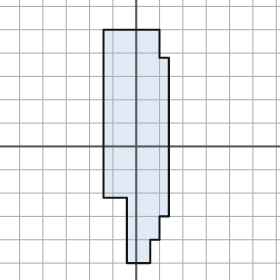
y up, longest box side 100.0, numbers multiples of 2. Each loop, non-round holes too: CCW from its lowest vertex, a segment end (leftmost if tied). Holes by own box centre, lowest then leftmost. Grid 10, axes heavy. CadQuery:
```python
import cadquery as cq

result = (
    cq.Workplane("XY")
    .moveTo(-4.0, -50.0)
    .lineTo(6.0, -50.0)
    .lineTo(6.0, -40.0)
    .lineTo(10.0, -40.0)
    .lineTo(10.0, -30.0)
    .lineTo(14.0, -30.0)
    .lineTo(14.0, 38.0)
    .lineTo(10.0, 38.0)
    .lineTo(10.0, 50.0)
    .lineTo(-14.0, 50.0)
    .lineTo(-14.0, -22.0)
    .lineTo(-4.0, -22.0)
    .close()
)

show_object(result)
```